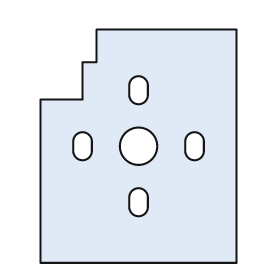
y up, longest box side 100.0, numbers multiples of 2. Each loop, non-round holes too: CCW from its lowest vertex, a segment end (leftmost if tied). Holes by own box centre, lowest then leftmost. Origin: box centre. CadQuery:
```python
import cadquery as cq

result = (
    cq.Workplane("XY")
    .moveTo(-42.0, -50.0)
    .lineTo(42.0, -50.0)
    .lineTo(42.0, 50.0)
    .lineTo(-18.0, 50.0)
    .lineTo(-18.0, 36.0)
    .lineTo(-24.0, 36.0)
    .lineTo(-24.0, 20.0)
    .lineTo(-42.0, 20.0)
    .close()
    .moveTo(-4.0, -26.0)
    .threePointArc((0.0, -30.0), (4.0, -26.0))
    .lineTo(4.0, -22.0)
    .threePointArc((0.0, -18.0), (-4.0, -22.0))
    .close()
    .moveTo(-28.0, -2.0)
    .threePointArc((-24.0, -6.0), (-20.0, -2.0))
    .lineTo(-20.0, 2.0)
    .threePointArc((-24.0, 6.0), (-28.0, 2.0))
    .close()
    .moveTo(0.0, 0.0)
    .circle(8.0)
    .moveTo(20.0, -2.0)
    .threePointArc((24.0, -6.0), (28.0, -2.0))
    .lineTo(28.0, 2.0)
    .threePointArc((24.0, 6.0), (20.0, 2.0))
    .close()
    .moveTo(-4.0, 22.0)
    .threePointArc((0.0, 18.0), (4.0, 22.0))
    .lineTo(4.0, 26.0)
    .threePointArc((0.0, 30.0), (-4.0, 26.0))
    .close()
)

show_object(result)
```